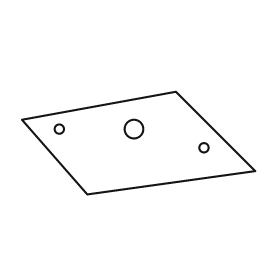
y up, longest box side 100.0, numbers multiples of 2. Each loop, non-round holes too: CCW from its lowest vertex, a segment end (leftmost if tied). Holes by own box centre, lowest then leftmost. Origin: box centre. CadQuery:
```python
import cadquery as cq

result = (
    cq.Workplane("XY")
    .moveTo(-22.0, -22.0)
    .lineTo(50.0, -12.0)
    .lineTo(16.0, 22.0)
    .lineTo(-50.0, 10.0)
    .close()
    .moveTo(28.0, -2.0)
    .circle(2.0)
    .moveTo(-34.0, 6.0)
    .circle(2.0)
    .moveTo(-2.0, 6.0)
    .circle(4.0)
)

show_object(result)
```